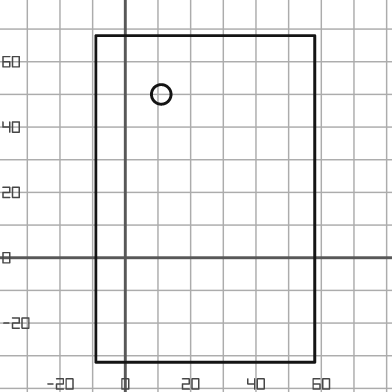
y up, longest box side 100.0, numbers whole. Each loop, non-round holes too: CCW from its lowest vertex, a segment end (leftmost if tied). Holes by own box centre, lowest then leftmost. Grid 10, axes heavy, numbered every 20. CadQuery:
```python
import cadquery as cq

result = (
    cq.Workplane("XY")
    .moveTo(-9.0, -32.0)
    .lineTo(58.0, -32.0)
    .lineTo(58.0, 68.0)
    .lineTo(-9.0, 68.0)
    .close()
    .moveTo(11.0, 50.0)
    .circle(3.0)
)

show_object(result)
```